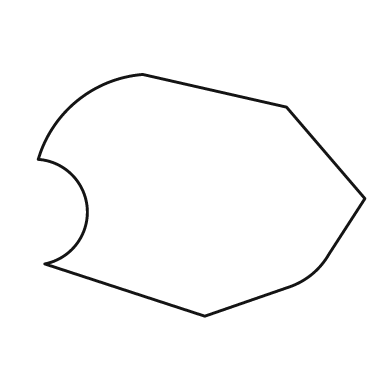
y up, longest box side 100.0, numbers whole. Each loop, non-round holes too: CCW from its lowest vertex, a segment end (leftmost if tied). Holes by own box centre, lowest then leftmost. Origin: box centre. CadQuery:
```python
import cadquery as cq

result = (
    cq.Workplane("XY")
    .moveTo(1.0, -37.0)
    .lineTo(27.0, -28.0)
    .threePointArc((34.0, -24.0), (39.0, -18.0))
    .lineTo(50.0, -1.0)
    .lineTo(26.0, 27.0)
    .lineTo(-18.0, 37.0)
    .threePointArc((-38.0, 29.0), (-50.0, 11.0))
    .threePointArc((-35.0, -4.0), (-48.0, -21.0))
    .close()
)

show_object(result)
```